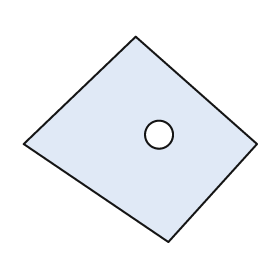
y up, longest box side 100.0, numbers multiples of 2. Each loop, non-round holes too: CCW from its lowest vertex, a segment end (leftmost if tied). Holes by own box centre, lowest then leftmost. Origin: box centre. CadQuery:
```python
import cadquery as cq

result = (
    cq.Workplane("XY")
    .moveTo(12.0, -44.0)
    .lineTo(50.0, -2.0)
    .lineTo(-2.0, 44.0)
    .lineTo(-50.0, -2.0)
    .close()
    .moveTo(8.0, 2.0)
    .circle(6.0)
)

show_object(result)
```